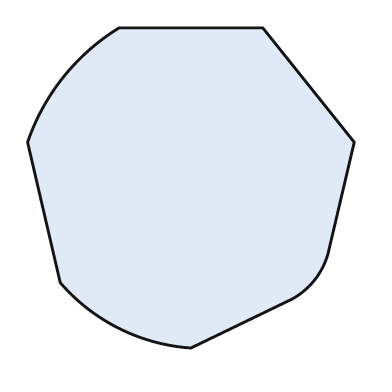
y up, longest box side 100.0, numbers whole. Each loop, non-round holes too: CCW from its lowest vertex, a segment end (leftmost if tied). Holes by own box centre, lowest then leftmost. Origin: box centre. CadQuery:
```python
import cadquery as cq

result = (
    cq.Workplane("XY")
    .moveTo(0.0, -49.0)
    .lineTo(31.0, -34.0)
    .threePointArc((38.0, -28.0), (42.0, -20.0))
    .lineTo(50.0, 14.0)
    .lineTo(22.0, 49.0)
    .lineTo(-22.0, 49.0)
    .threePointArc((-39.0, 34.0), (-50.0, 14.0))
    .lineTo(-40.0, -29.0)
    .threePointArc((-22.0, -43.0), (0.0, -49.0))
    .close()
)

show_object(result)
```